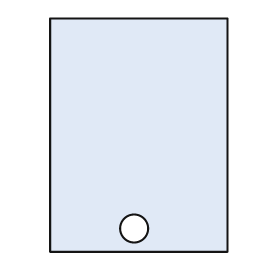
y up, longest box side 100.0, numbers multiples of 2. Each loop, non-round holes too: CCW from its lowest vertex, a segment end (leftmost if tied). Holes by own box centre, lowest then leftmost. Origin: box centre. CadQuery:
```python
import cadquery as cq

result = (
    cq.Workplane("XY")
    .moveTo(-38.0, -50.0)
    .lineTo(38.0, -50.0)
    .lineTo(38.0, 50.0)
    .lineTo(-38.0, 50.0)
    .close()
    .moveTo(-2.0, -40.0)
    .circle(6.0)
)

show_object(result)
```